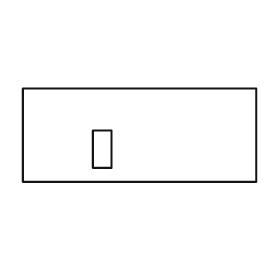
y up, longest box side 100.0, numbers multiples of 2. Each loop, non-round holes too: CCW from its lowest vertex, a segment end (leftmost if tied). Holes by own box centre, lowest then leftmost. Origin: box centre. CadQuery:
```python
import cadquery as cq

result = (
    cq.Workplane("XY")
    .moveTo(-50.0, -20.0)
    .lineTo(50.0, -20.0)
    .lineTo(50.0, 20.0)
    .lineTo(-50.0, 20.0)
    .close()
    .moveTo(-20.0, -14.0)
    .lineTo(-12.0, -14.0)
    .lineTo(-12.0, 2.0)
    .lineTo(-20.0, 2.0)
    .close()
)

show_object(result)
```